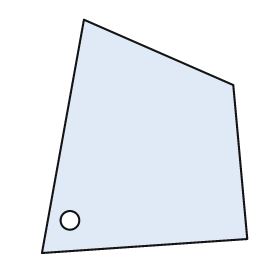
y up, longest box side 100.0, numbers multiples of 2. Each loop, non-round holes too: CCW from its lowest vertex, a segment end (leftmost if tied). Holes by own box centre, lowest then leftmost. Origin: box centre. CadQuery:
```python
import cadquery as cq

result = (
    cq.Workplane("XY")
    .moveTo(-44.0, -50.0)
    .lineTo(44.0, -44.0)
    .lineTo(38.0, 22.0)
    .lineTo(-26.0, 50.0)
    .close()
    .moveTo(-32.0, -36.0)
    .circle(4.0)
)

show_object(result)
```